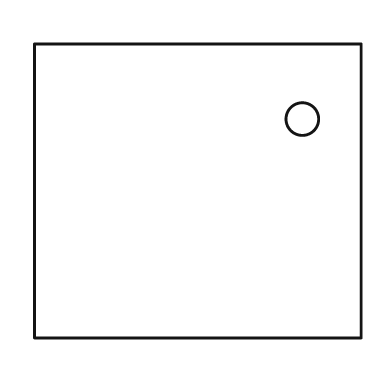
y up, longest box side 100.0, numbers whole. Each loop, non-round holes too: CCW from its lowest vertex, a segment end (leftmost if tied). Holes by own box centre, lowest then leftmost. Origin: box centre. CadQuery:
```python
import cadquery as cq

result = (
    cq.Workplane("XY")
    .moveTo(-50.0, -45.0)
    .lineTo(50.0, -45.0)
    .lineTo(50.0, 45.0)
    .lineTo(-50.0, 45.0)
    .close()
    .moveTo(32.0, 22.0)
    .circle(5.0)
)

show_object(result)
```